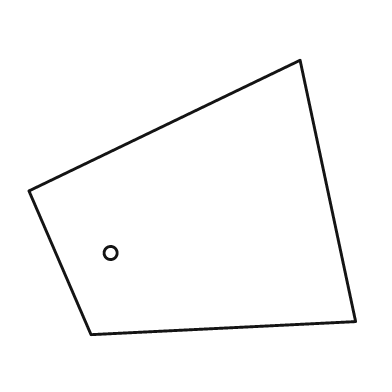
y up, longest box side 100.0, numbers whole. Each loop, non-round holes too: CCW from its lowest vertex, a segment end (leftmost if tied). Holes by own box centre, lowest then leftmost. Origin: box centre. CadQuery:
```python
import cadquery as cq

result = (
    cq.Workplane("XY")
    .moveTo(-31.0, -42.0)
    .lineTo(50.0, -38.0)
    .lineTo(33.0, 42.0)
    .lineTo(-50.0, 2.0)
    .close()
    .moveTo(-25.0, -17.0)
    .circle(2.0)
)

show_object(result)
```